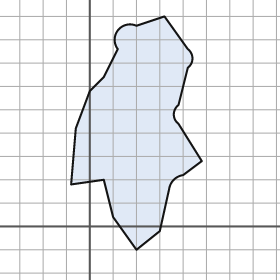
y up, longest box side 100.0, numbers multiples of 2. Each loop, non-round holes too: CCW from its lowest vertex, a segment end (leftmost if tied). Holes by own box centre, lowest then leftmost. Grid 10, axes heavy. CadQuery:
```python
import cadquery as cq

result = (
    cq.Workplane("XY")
    .moveTo(20.0, -10.0)
    .lineTo(30.0, -2.0)
    .lineTo(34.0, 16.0)
    .threePointArc((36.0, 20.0), (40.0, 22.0))
    .lineTo(48.0, 28.0)
    .lineTo(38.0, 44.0)
    .threePointArc((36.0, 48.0), (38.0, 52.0))
    .lineTo(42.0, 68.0)
    .threePointArc((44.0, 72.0), (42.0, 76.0))
    .lineTo(32.0, 90.0)
    .lineTo(20.0, 86.0)
    .threePointArc((12.0, 84.0), (12.0, 76.0))
    .lineTo(6.0, 64.0)
    .lineTo(0.0, 58.0)
    .lineTo(-6.0, 42.0)
    .lineTo(-8.0, 18.0)
    .lineTo(6.0, 20.0)
    .lineTo(10.0, 4.0)
    .close()
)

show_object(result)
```